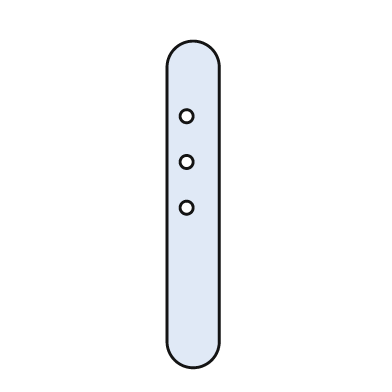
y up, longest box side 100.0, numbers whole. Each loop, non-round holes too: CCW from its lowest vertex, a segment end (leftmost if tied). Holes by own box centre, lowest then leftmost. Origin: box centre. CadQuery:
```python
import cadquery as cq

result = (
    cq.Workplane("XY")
    .moveTo(-8.0, -42.0)
    .threePointArc((0.0, -50.0), (8.0, -42.0))
    .lineTo(8.0, 42.0)
    .threePointArc((0.0, 50.0), (-8.0, 42.0))
    .close()
    .moveTo(-2.0, -1.0)
    .circle(2.0)
    .moveTo(-2.0, 13.0)
    .circle(2.0)
    .moveTo(-2.0, 27.0)
    .circle(2.0)
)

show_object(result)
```